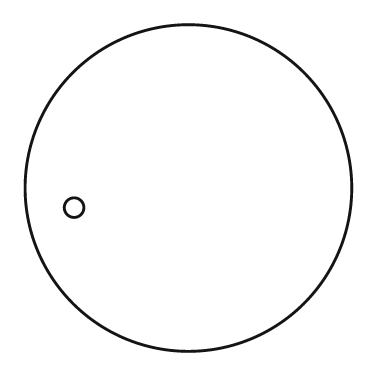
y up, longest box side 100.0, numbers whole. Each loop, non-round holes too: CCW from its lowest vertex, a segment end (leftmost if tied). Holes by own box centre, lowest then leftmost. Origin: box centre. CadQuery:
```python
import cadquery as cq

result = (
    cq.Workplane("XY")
    .moveTo(0.0, 0.0)
    .circle(50.0)
    .moveTo(-35.0, -6.0)
    .circle(3.0)
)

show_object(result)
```